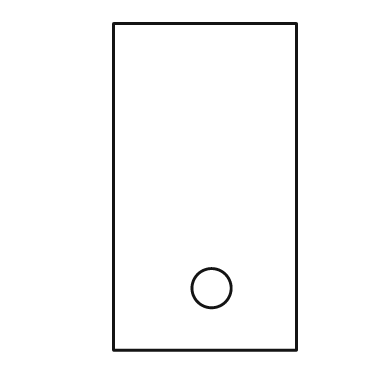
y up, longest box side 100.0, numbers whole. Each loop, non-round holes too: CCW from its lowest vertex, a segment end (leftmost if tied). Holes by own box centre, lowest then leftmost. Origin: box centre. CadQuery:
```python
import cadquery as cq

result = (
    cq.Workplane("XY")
    .moveTo(-28.0, -50.0)
    .lineTo(28.0, -50.0)
    .lineTo(28.0, 50.0)
    .lineTo(-28.0, 50.0)
    .close()
    .moveTo(2.0, -31.0)
    .circle(6.0)
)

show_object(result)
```